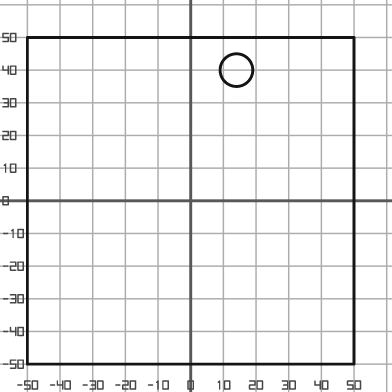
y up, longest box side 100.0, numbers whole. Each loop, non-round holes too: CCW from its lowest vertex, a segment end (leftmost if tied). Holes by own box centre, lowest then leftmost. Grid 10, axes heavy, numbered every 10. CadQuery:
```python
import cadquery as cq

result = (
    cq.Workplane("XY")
    .moveTo(-50.0, -50.0)
    .lineTo(50.0, -50.0)
    .lineTo(50.0, 50.0)
    .lineTo(-50.0, 50.0)
    .close()
    .moveTo(14.0, 40.0)
    .circle(5.0)
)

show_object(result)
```